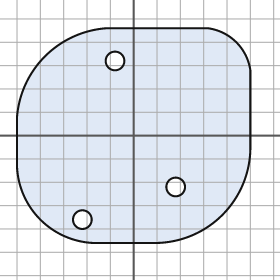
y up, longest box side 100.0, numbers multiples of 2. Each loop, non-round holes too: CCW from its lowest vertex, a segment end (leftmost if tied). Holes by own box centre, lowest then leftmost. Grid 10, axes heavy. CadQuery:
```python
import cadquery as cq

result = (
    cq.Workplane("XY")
    .moveTo(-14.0, -46.0)
    .lineTo(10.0, -46.0)
    .threePointArc((38.0, -34.0), (50.0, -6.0))
    .lineTo(50.0, 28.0)
    .threePointArc((44.0, 40.0), (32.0, 46.0))
    .lineTo(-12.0, 46.0)
    .threePointArc((-38.0, 34.0), (-50.0, 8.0))
    .lineTo(-50.0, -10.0)
    .threePointArc((-40.0, -36.0), (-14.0, -46.0))
    .close()
    .moveTo(-22.0, -36.0)
    .circle(4.0)
    .moveTo(18.0, -22.0)
    .circle(4.0)
    .moveTo(-8.0, 32.0)
    .circle(4.0)
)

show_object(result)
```